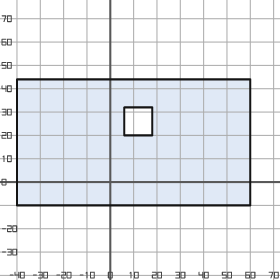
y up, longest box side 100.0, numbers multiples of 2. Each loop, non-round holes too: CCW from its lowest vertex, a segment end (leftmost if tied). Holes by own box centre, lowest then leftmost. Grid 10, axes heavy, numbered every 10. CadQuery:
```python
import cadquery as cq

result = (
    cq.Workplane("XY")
    .moveTo(-40.0, -10.0)
    .lineTo(60.0, -10.0)
    .lineTo(60.0, 44.0)
    .lineTo(-40.0, 44.0)
    .close()
    .moveTo(6.0, 20.0)
    .lineTo(18.0, 20.0)
    .lineTo(18.0, 32.0)
    .lineTo(6.0, 32.0)
    .close()
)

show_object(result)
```